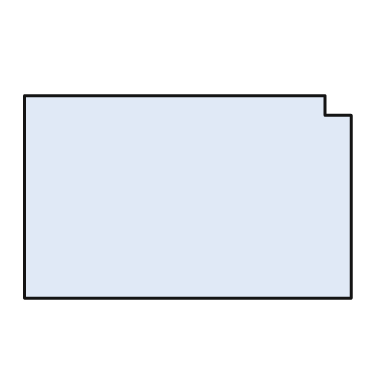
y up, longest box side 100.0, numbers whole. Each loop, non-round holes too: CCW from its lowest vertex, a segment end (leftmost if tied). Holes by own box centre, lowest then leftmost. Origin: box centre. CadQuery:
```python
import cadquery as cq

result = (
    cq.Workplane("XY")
    .moveTo(-50.0, -31.0)
    .lineTo(50.0, -31.0)
    .lineTo(50.0, 25.0)
    .lineTo(42.0, 25.0)
    .lineTo(42.0, 31.0)
    .lineTo(-50.0, 31.0)
    .close()
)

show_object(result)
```